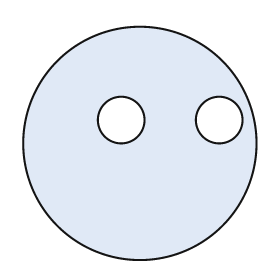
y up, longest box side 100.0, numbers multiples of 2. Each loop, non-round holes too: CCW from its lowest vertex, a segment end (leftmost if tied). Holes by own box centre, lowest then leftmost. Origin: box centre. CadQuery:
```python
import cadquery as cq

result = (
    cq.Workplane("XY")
    .moveTo(0.0, 0.0)
    .circle(50.0)
    .moveTo(-8.0, 10.0)
    .circle(10.0)
    .moveTo(34.0, 10.0)
    .circle(10.0)
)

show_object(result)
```